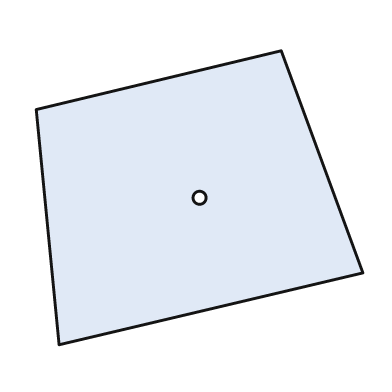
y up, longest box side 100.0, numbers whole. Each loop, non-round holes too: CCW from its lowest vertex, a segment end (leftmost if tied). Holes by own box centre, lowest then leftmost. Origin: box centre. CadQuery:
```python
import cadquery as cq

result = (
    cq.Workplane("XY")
    .moveTo(-43.0, -45.0)
    .lineTo(50.0, -23.0)
    .lineTo(25.0, 45.0)
    .lineTo(-50.0, 27.0)
    .close()
    .moveTo(0.0, 0.0)
    .circle(2.0)
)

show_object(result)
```